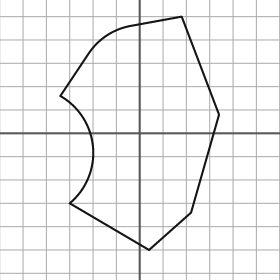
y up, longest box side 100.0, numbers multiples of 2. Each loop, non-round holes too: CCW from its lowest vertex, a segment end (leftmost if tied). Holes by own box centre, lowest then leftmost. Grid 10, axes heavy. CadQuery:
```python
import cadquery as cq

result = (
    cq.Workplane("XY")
    .moveTo(4.0, -50.0)
    .lineTo(22.0, -34.0)
    .lineTo(34.0, 8.0)
    .lineTo(18.0, 50.0)
    .lineTo(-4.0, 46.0)
    .threePointArc((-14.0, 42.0), (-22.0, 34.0))
    .lineTo(-34.0, 16.0)
    .threePointArc((-20.0, -6.0), (-30.0, -30.0))
    .close()
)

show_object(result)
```